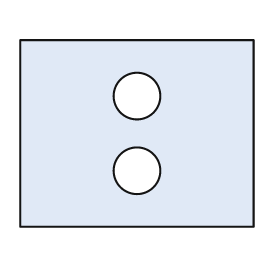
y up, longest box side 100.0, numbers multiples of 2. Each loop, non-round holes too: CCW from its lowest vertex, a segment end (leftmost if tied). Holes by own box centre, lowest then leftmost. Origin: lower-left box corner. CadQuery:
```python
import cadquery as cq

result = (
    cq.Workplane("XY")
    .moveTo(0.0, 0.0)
    .lineTo(100.0, 0.0)
    .lineTo(100.0, 80.0)
    .lineTo(0.0, 80.0)
    .close()
    .moveTo(50.0, 24.0)
    .circle(10.0)
    .moveTo(50.0, 56.0)
    .circle(10.0)
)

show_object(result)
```